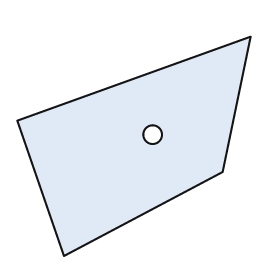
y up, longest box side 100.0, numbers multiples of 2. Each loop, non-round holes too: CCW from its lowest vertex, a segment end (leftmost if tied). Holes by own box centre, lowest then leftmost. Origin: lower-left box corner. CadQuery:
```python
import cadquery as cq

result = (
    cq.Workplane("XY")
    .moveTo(20.0, 0.0)
    .lineTo(88.0, 36.0)
    .lineTo(100.0, 94.0)
    .lineTo(0.0, 58.0)
    .close()
    .moveTo(58.0, 52.0)
    .circle(4.0)
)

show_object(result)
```